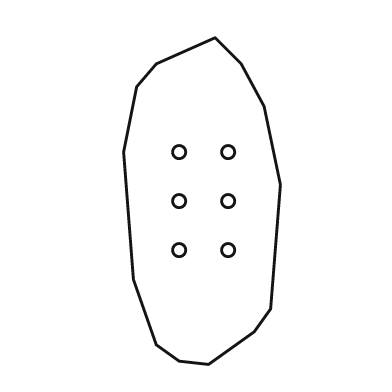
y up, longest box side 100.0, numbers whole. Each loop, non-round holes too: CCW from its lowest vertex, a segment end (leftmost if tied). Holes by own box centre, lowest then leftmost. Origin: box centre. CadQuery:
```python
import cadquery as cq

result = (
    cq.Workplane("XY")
    .moveTo(2.0, -50.0)
    .lineTo(16.0, -40.0)
    .lineTo(21.0, -33.0)
    .lineTo(24.0, 5.0)
    .lineTo(19.0, 29.0)
    .lineTo(12.0, 42.0)
    .lineTo(4.0, 50.0)
    .lineTo(-14.0, 42.0)
    .lineTo(-20.0, 35.0)
    .lineTo(-24.0, 15.0)
    .lineTo(-21.0, -24.0)
    .lineTo(-14.0, -44.0)
    .lineTo(-7.0, -49.0)
    .close()
    .moveTo(-7.0, -15.0)
    .circle(2.0)
    .moveTo(8.0, -15.0)
    .circle(2.0)
    .moveTo(-7.0, 0.0)
    .circle(2.0)
    .moveTo(8.0, 0.0)
    .circle(2.0)
    .moveTo(-7.0, 15.0)
    .circle(2.0)
    .moveTo(8.0, 15.0)
    .circle(2.0)
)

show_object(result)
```